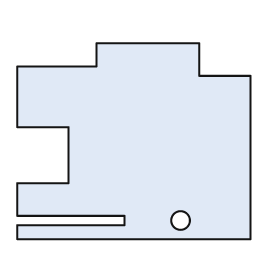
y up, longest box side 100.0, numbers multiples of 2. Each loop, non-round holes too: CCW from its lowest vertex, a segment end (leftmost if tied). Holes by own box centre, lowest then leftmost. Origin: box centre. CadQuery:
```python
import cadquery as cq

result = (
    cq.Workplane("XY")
    .moveTo(-50.0, -42.0)
    .lineTo(50.0, -42.0)
    .lineTo(50.0, 28.0)
    .lineTo(28.0, 28.0)
    .lineTo(28.0, 42.0)
    .lineTo(-16.0, 42.0)
    .lineTo(-16.0, 32.0)
    .lineTo(-50.0, 32.0)
    .lineTo(-50.0, 6.0)
    .lineTo(-28.0, 6.0)
    .lineTo(-28.0, -18.0)
    .lineTo(-50.0, -18.0)
    .lineTo(-50.0, -32.0)
    .lineTo(-4.0, -32.0)
    .lineTo(-4.0, -36.0)
    .lineTo(-50.0, -36.0)
    .close()
    .moveTo(20.0, -34.0)
    .circle(4.0)
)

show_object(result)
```